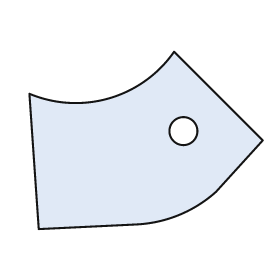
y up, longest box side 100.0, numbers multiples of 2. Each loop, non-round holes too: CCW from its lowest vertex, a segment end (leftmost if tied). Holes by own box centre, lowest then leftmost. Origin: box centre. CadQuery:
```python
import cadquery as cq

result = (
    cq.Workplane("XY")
    .moveTo(-46.0, -38.0)
    .lineTo(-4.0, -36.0)
    .threePointArc((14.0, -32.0), (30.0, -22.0))
    .lineTo(50.0, 0.0)
    .lineTo(12.0, 38.0)
    .threePointArc((-16.0, 18.0), (-50.0, 20.0))
    .close()
    .moveTo(16.0, 4.0)
    .circle(6.0)
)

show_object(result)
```